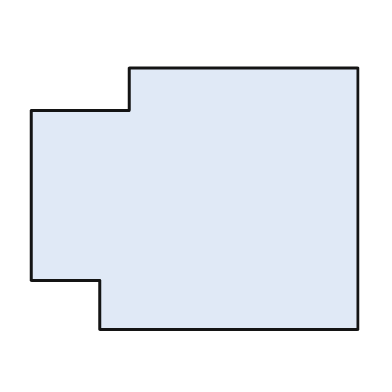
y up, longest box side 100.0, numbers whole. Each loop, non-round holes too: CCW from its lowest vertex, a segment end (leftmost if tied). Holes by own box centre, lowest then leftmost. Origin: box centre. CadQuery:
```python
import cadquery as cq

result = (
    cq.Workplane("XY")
    .moveTo(-29.0, -40.0)
    .lineTo(50.0, -40.0)
    .lineTo(50.0, 40.0)
    .lineTo(-20.0, 40.0)
    .lineTo(-20.0, 27.0)
    .lineTo(-50.0, 27.0)
    .lineTo(-50.0, -25.0)
    .lineTo(-29.0, -25.0)
    .close()
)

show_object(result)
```